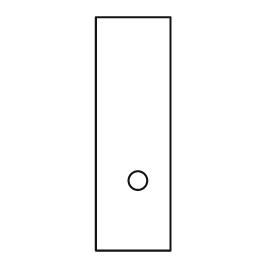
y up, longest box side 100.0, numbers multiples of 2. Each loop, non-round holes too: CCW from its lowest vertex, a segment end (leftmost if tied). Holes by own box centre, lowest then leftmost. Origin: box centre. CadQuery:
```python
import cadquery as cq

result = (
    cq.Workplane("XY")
    .moveTo(-16.0, -50.0)
    .lineTo(16.0, -50.0)
    .lineTo(16.0, 50.0)
    .lineTo(-16.0, 50.0)
    .close()
    .moveTo(2.0, -20.0)
    .circle(4.0)
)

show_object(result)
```